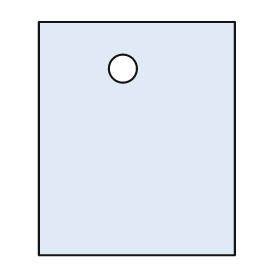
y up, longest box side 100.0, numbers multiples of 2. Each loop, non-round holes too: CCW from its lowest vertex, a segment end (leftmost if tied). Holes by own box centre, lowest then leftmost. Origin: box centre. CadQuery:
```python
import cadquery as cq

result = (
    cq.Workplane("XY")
    .moveTo(-42.0, -50.0)
    .lineTo(42.0, -50.0)
    .lineTo(42.0, 50.0)
    .lineTo(-42.0, 50.0)
    .close()
    .moveTo(-6.0, 30.0)
    .circle(6.0)
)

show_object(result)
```